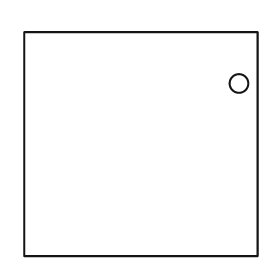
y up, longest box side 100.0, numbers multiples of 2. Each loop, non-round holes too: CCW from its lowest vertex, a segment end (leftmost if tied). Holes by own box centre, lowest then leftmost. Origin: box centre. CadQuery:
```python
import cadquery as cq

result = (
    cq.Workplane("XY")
    .moveTo(-50.0, -48.0)
    .lineTo(50.0, -48.0)
    .lineTo(50.0, 48.0)
    .lineTo(-50.0, 48.0)
    .close()
    .moveTo(42.0, 26.0)
    .circle(4.0)
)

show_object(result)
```